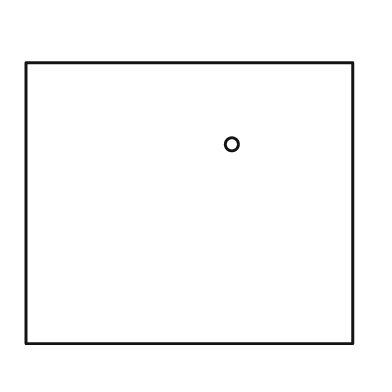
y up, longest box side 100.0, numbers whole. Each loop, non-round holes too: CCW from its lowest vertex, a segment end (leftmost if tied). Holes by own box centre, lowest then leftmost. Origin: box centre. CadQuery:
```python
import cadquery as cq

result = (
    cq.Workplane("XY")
    .moveTo(-50.0, -43.0)
    .lineTo(50.0, -43.0)
    .lineTo(50.0, 43.0)
    .lineTo(-50.0, 43.0)
    .close()
    .moveTo(13.0, 18.0)
    .circle(2.0)
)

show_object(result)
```